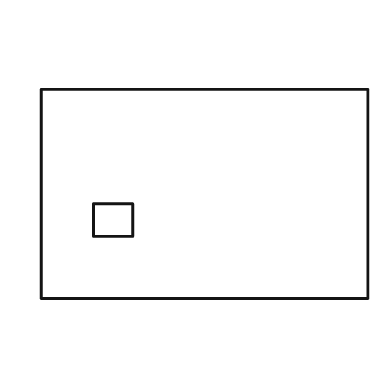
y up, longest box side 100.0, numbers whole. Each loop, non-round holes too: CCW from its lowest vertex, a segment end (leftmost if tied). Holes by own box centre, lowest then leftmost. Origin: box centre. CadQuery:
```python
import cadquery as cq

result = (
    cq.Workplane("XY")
    .moveTo(-50.0, -32.0)
    .lineTo(50.0, -32.0)
    .lineTo(50.0, 32.0)
    .lineTo(-50.0, 32.0)
    .close()
    .moveTo(-34.0, -13.0)
    .lineTo(-22.0, -13.0)
    .lineTo(-22.0, -3.0)
    .lineTo(-34.0, -3.0)
    .close()
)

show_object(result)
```